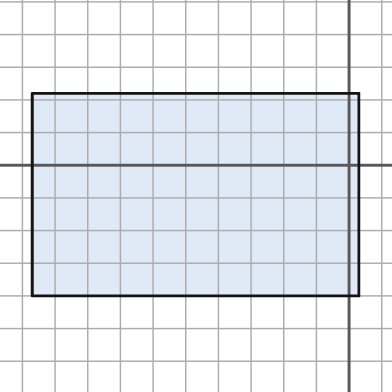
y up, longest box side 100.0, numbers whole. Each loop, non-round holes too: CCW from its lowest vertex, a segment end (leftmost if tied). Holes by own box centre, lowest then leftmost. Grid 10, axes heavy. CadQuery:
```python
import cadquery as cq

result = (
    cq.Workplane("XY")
    .moveTo(-97.0, -40.0)
    .lineTo(3.0, -40.0)
    .lineTo(3.0, 22.0)
    .lineTo(-97.0, 22.0)
    .close()
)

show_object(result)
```